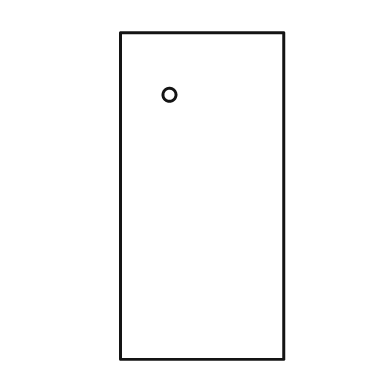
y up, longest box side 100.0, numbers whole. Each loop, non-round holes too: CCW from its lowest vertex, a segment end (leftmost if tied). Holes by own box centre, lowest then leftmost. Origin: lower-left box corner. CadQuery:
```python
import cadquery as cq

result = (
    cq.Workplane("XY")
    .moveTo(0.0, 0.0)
    .lineTo(50.0, 0.0)
    .lineTo(50.0, 100.0)
    .lineTo(0.0, 100.0)
    .close()
    .moveTo(15.0, 81.0)
    .circle(2.0)
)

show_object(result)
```